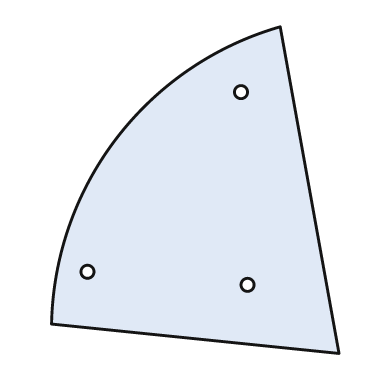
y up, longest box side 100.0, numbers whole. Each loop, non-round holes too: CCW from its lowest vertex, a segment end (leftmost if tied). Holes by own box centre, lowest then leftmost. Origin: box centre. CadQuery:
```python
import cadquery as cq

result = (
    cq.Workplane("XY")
    .moveTo(44.0, -50.0)
    .lineTo(26.0, 50.0)
    .threePointArc((-24.0, 16.0), (-44.0, -41.0))
    .close()
    .moveTo(16.0, -29.0)
    .circle(2.0)
    .moveTo(-33.0, -25.0)
    .circle(2.0)
    .moveTo(14.0, 30.0)
    .circle(2.0)
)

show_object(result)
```